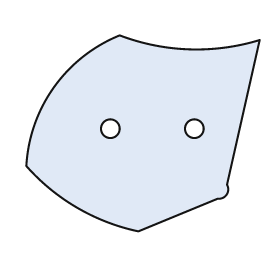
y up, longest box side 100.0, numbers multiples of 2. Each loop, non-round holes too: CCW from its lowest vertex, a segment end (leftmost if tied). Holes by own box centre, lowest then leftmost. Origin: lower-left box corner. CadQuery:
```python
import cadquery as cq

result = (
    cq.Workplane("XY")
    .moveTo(48.0, 0.0)
    .lineTo(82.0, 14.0)
    .threePointArc((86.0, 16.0), (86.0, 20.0))
    .lineTo(100.0, 82.0)
    .threePointArc((70.0, 78.0), (40.0, 84.0))
    .threePointArc((12.0, 62.0), (0.0, 28.0))
    .threePointArc((22.0, 10.0), (48.0, 0.0))
    .close()
    .moveTo(36.0, 44.0)
    .circle(4.0)
    .moveTo(72.0, 44.0)
    .circle(4.0)
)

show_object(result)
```